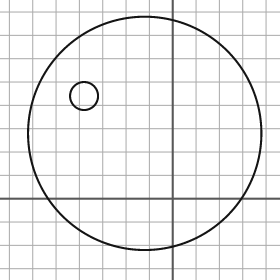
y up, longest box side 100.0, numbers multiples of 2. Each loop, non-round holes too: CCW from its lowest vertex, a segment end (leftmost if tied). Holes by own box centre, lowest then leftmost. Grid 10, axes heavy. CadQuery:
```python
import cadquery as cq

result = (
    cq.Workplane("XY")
    .moveTo(-12.0, 28.0)
    .circle(50.0)
    .moveTo(-38.0, 44.0)
    .circle(6.0)
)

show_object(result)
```